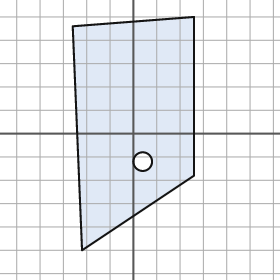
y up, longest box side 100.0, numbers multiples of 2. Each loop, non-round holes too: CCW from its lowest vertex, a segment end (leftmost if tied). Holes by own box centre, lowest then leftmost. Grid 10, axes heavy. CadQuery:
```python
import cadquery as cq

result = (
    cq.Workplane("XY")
    .moveTo(-22.0, -50.0)
    .lineTo(26.0, -18.0)
    .lineTo(26.0, 50.0)
    .lineTo(-26.0, 46.0)
    .close()
    .moveTo(4.0, -12.0)
    .circle(4.0)
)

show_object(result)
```